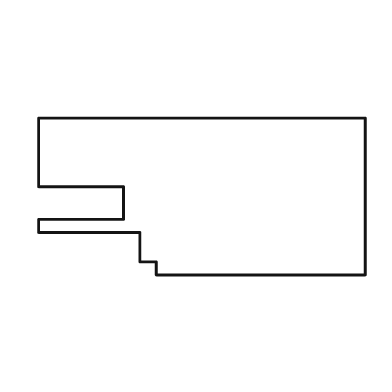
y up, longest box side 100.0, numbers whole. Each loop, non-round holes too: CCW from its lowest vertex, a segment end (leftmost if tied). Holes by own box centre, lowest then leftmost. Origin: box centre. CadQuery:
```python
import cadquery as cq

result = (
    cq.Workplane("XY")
    .moveTo(-14.0, -24.0)
    .lineTo(50.0, -24.0)
    .lineTo(50.0, 24.0)
    .lineTo(-50.0, 24.0)
    .lineTo(-50.0, 3.0)
    .lineTo(-24.0, 3.0)
    .lineTo(-24.0, -7.0)
    .lineTo(-50.0, -7.0)
    .lineTo(-50.0, -11.0)
    .lineTo(-19.0, -11.0)
    .lineTo(-19.0, -20.0)
    .lineTo(-14.0, -20.0)
    .close()
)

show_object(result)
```